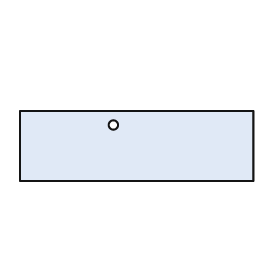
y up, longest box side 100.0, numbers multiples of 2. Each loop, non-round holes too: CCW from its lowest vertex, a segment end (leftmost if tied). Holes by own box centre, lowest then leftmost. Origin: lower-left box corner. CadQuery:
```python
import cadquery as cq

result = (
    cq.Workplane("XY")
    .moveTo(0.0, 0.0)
    .lineTo(100.0, 0.0)
    .lineTo(100.0, 30.0)
    .lineTo(0.0, 30.0)
    .close()
    .moveTo(40.0, 24.0)
    .circle(2.0)
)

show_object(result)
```